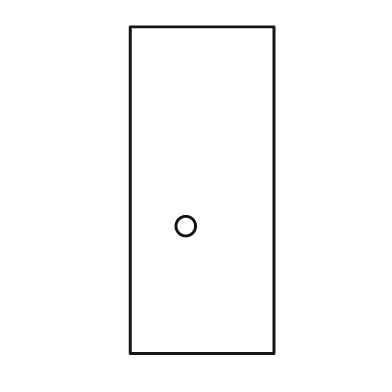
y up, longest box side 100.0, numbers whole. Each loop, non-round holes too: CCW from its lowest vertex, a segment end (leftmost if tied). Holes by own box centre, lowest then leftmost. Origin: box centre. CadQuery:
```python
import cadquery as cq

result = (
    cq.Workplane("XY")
    .moveTo(-22.0, -50.0)
    .lineTo(22.0, -50.0)
    .lineTo(22.0, 50.0)
    .lineTo(-22.0, 50.0)
    .close()
    .moveTo(-5.0, -11.0)
    .circle(3.0)
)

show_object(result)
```